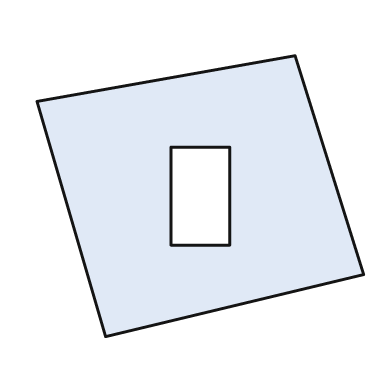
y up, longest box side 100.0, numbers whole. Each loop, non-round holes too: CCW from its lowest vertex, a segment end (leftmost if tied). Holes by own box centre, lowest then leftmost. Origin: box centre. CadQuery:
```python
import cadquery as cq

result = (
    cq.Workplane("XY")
    .moveTo(-29.0, -43.0)
    .lineTo(50.0, -24.0)
    .lineTo(29.0, 43.0)
    .lineTo(-50.0, 29.0)
    .close()
    .moveTo(-9.0, -15.0)
    .lineTo(9.0, -15.0)
    .lineTo(9.0, 15.0)
    .lineTo(-9.0, 15.0)
    .close()
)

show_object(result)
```